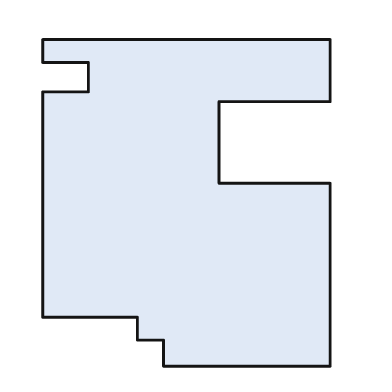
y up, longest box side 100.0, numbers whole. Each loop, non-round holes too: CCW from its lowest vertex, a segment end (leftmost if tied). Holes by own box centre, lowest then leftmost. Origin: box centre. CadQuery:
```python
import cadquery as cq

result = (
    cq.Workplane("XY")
    .moveTo(-7.0, -50.0)
    .lineTo(44.0, -50.0)
    .lineTo(44.0, 6.0)
    .lineTo(10.0, 6.0)
    .lineTo(10.0, 31.0)
    .lineTo(44.0, 31.0)
    .lineTo(44.0, 50.0)
    .lineTo(-44.0, 50.0)
    .lineTo(-44.0, 43.0)
    .lineTo(-30.0, 43.0)
    .lineTo(-30.0, 34.0)
    .lineTo(-44.0, 34.0)
    .lineTo(-44.0, -35.0)
    .lineTo(-15.0, -35.0)
    .lineTo(-15.0, -42.0)
    .lineTo(-7.0, -42.0)
    .close()
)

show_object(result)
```